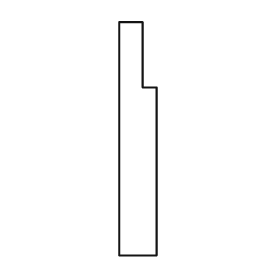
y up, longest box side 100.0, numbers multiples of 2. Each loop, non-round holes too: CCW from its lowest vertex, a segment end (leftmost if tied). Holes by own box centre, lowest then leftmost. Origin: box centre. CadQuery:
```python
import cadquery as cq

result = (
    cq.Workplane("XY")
    .moveTo(-8.0, -50.0)
    .lineTo(8.0, -50.0)
    .lineTo(8.0, 22.0)
    .lineTo(2.0, 22.0)
    .lineTo(2.0, 50.0)
    .lineTo(-8.0, 50.0)
    .close()
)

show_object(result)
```